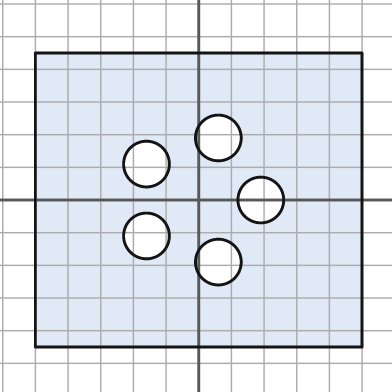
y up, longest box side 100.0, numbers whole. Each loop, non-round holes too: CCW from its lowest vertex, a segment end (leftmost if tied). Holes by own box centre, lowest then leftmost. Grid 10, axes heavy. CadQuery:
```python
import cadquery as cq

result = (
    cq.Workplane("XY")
    .moveTo(-50.0, -45.0)
    .lineTo(50.0, -45.0)
    .lineTo(50.0, 45.0)
    .lineTo(-50.0, 45.0)
    .close()
    .moveTo(6.0, -19.0)
    .circle(7.0)
    .moveTo(-16.0, -11.0)
    .circle(7.0)
    .moveTo(19.0, 0.0)
    .circle(7.0)
    .moveTo(-16.0, 11.0)
    .circle(7.0)
    .moveTo(6.0, 19.0)
    .circle(7.0)
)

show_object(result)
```